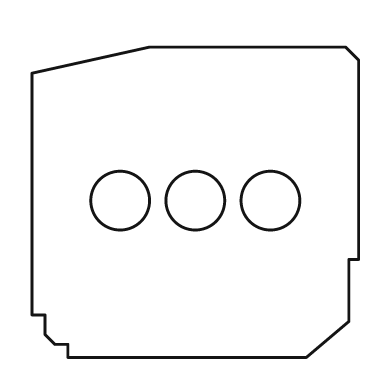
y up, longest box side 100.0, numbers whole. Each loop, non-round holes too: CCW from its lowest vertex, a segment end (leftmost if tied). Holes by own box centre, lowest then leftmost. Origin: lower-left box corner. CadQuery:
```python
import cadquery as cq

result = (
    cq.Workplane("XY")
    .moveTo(11.0, 0.0)
    .lineTo(84.0, 0.0)
    .lineTo(97.0, 11.0)
    .lineTo(97.0, 30.0)
    .lineTo(100.0, 30.0)
    .lineTo(100.0, 91.0)
    .lineTo(96.0, 95.0)
    .lineTo(36.0, 95.0)
    .lineTo(0.0, 87.0)
    .lineTo(0.0, 13.0)
    .lineTo(4.0, 13.0)
    .lineTo(4.0, 7.0)
    .lineTo(7.0, 4.0)
    .lineTo(11.0, 4.0)
    .close()
    .moveTo(27.0, 48.0)
    .circle(9.0)
    .moveTo(50.0, 48.0)
    .circle(9.0)
    .moveTo(73.0, 48.0)
    .circle(9.0)
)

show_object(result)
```